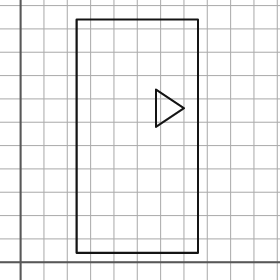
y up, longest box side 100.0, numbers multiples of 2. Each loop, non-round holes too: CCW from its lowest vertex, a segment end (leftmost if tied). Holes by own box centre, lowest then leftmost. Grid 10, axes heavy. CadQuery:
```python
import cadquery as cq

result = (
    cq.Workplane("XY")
    .moveTo(24.0, 4.0)
    .lineTo(76.0, 4.0)
    .lineTo(76.0, 104.0)
    .lineTo(24.0, 104.0)
    .close()
    .moveTo(58.0, 58.0)
    .lineTo(70.0, 66.0)
    .lineTo(58.0, 74.0)
    .close()
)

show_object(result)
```